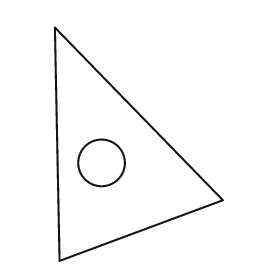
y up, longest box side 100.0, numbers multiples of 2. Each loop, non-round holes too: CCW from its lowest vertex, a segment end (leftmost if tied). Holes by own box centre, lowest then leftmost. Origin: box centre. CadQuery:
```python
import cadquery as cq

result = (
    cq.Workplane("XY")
    .moveTo(-34.0, -50.0)
    .lineTo(36.0, -24.0)
    .lineTo(-36.0, 50.0)
    .close()
    .moveTo(-16.0, -8.0)
    .circle(10.0)
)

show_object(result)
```